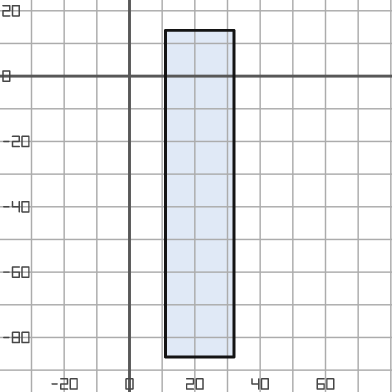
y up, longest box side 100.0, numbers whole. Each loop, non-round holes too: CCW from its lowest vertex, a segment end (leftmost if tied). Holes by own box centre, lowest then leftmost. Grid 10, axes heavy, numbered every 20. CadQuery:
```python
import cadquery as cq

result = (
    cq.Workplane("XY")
    .moveTo(11.0, -86.0)
    .lineTo(32.0, -86.0)
    .lineTo(32.0, 14.0)
    .lineTo(11.0, 14.0)
    .close()
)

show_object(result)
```